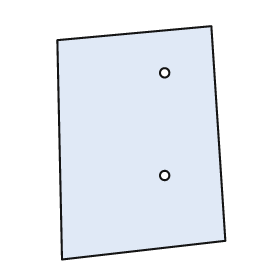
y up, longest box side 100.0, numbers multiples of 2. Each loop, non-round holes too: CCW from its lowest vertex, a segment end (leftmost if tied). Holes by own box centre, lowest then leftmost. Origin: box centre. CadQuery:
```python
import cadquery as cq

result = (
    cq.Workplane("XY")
    .moveTo(-34.0, -50.0)
    .lineTo(36.0, -42.0)
    .lineTo(30.0, 50.0)
    .lineTo(-36.0, 44.0)
    .close()
    .moveTo(10.0, -14.0)
    .circle(2.0)
    .moveTo(10.0, 30.0)
    .circle(2.0)
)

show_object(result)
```